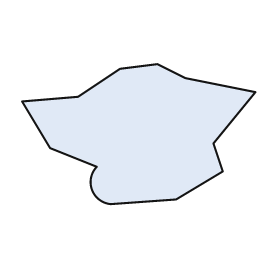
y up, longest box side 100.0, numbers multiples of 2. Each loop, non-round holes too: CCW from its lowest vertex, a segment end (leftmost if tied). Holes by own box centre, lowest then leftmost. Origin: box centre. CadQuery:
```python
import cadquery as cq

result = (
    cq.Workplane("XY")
    .moveTo(-12.0, -30.0)
    .lineTo(16.0, -28.0)
    .lineTo(36.0, -16.0)
    .lineTo(32.0, -4.0)
    .lineTo(50.0, 18.0)
    .lineTo(20.0, 24.0)
    .lineTo(8.0, 30.0)
    .lineTo(-8.0, 28.0)
    .lineTo(-26.0, 16.0)
    .lineTo(-50.0, 14.0)
    .lineTo(-38.0, -6.0)
    .lineTo(-18.0, -14.0)
    .threePointArc((-20.0, -24.0), (-12.0, -30.0))
    .close()
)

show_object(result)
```